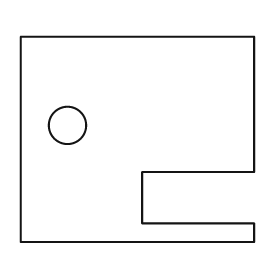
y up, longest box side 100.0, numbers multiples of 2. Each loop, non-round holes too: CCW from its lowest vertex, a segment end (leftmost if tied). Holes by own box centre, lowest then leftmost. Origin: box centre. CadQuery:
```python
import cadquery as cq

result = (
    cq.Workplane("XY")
    .moveTo(-50.0, -44.0)
    .lineTo(50.0, -44.0)
    .lineTo(50.0, -36.0)
    .lineTo(2.0, -36.0)
    .lineTo(2.0, -14.0)
    .lineTo(50.0, -14.0)
    .lineTo(50.0, 44.0)
    .lineTo(-50.0, 44.0)
    .close()
    .moveTo(-30.0, 6.0)
    .circle(8.0)
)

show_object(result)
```